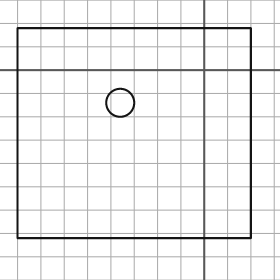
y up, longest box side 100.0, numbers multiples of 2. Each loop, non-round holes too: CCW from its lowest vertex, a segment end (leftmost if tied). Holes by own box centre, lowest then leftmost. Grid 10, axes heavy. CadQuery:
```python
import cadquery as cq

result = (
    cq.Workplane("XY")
    .moveTo(-80.0, -72.0)
    .lineTo(20.0, -72.0)
    .lineTo(20.0, 18.0)
    .lineTo(-80.0, 18.0)
    .close()
    .moveTo(-36.0, -14.0)
    .circle(6.0)
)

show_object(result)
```